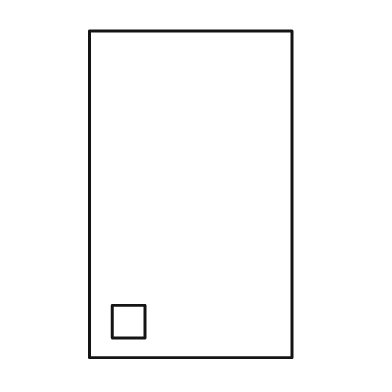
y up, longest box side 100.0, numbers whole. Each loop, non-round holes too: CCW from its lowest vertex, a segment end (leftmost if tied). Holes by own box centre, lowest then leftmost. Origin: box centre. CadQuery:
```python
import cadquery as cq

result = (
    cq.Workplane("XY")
    .moveTo(-31.0, -50.0)
    .lineTo(31.0, -50.0)
    .lineTo(31.0, 50.0)
    .lineTo(-31.0, 50.0)
    .close()
    .moveTo(-24.0, -44.0)
    .lineTo(-14.0, -44.0)
    .lineTo(-14.0, -34.0)
    .lineTo(-24.0, -34.0)
    .close()
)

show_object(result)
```